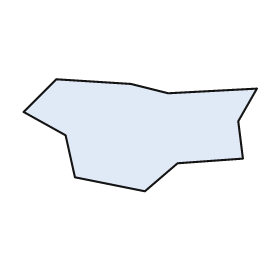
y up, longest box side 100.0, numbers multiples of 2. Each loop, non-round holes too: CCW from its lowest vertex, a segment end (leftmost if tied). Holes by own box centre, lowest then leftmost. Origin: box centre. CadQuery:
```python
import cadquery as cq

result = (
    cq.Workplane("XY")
    .moveTo(2.0, -24.0)
    .lineTo(16.0, -12.0)
    .lineTo(44.0, -10.0)
    .lineTo(42.0, 6.0)
    .lineTo(50.0, 20.0)
    .lineTo(12.0, 18.0)
    .lineTo(-4.0, 22.0)
    .lineTo(-36.0, 24.0)
    .lineTo(-50.0, 10.0)
    .lineTo(-32.0, 0.0)
    .lineTo(-28.0, -18.0)
    .close()
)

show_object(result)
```